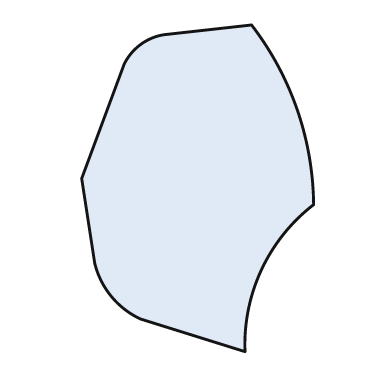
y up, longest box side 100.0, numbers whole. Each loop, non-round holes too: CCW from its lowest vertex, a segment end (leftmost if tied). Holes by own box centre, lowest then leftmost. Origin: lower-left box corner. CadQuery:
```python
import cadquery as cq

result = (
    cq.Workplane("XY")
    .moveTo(50.0, 0.0)
    .threePointArc((55.0, 25.0), (71.0, 45.0))
    .threePointArc((66.0, 74.0), (52.0, 100.0))
    .lineTo(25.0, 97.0)
    .threePointArc((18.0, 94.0), (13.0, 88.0))
    .lineTo(0.0, 53.0)
    .lineTo(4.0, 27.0)
    .threePointArc((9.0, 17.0), (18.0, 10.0))
    .close()
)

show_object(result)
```